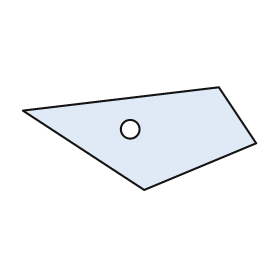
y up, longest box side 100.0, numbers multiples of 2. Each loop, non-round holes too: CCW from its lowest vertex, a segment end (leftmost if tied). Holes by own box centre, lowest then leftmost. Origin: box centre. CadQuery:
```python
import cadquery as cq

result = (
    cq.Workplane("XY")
    .moveTo(2.0, -22.0)
    .lineTo(50.0, -2.0)
    .lineTo(34.0, 22.0)
    .lineTo(-50.0, 12.0)
    .close()
    .moveTo(-4.0, 4.0)
    .circle(4.0)
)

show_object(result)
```